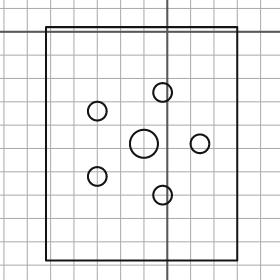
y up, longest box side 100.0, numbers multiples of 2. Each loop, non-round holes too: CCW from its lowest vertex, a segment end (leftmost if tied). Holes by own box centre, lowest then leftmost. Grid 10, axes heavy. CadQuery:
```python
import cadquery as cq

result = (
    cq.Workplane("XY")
    .moveTo(-52.0, -98.0)
    .lineTo(30.0, -98.0)
    .lineTo(30.0, 2.0)
    .lineTo(-52.0, 2.0)
    .close()
    .moveTo(-2.0, -70.0)
    .circle(4.0)
    .moveTo(-30.0, -62.0)
    .circle(4.0)
    .moveTo(-10.0, -48.0)
    .circle(6.0)
    .moveTo(14.0, -48.0)
    .circle(4.0)
    .moveTo(-30.0, -34.0)
    .circle(4.0)
    .moveTo(-2.0, -26.0)
    .circle(4.0)
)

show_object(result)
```